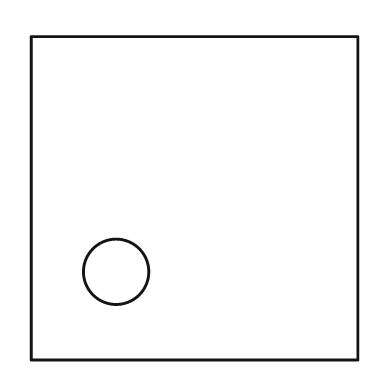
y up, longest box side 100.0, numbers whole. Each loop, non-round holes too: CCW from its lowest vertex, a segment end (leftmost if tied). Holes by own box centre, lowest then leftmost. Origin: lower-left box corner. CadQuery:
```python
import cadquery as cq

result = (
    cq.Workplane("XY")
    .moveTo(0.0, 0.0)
    .lineTo(100.0, 0.0)
    .lineTo(100.0, 99.0)
    .lineTo(0.0, 99.0)
    .close()
    .moveTo(26.0, 27.0)
    .circle(10.0)
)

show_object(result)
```